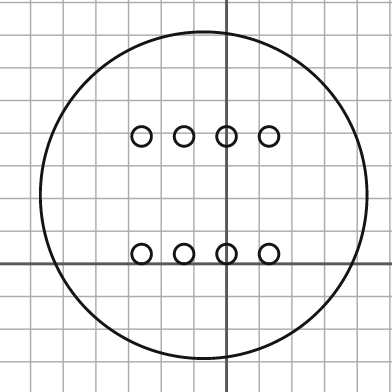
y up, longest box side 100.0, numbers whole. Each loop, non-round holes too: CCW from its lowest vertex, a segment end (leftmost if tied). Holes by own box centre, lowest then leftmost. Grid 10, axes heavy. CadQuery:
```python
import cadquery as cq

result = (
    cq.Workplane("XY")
    .moveTo(-7.0, 21.0)
    .circle(50.0)
    .moveTo(-26.0, 3.0)
    .circle(3.0)
    .moveTo(-13.0, 3.0)
    .circle(3.0)
    .moveTo(0.0, 3.0)
    .circle(3.0)
    .moveTo(13.0, 3.0)
    .circle(3.0)
    .moveTo(-26.0, 39.0)
    .circle(3.0)
    .moveTo(-13.0, 39.0)
    .circle(3.0)
    .moveTo(0.0, 39.0)
    .circle(3.0)
    .moveTo(13.0, 39.0)
    .circle(3.0)
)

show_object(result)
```